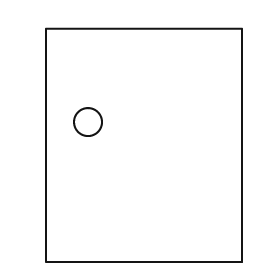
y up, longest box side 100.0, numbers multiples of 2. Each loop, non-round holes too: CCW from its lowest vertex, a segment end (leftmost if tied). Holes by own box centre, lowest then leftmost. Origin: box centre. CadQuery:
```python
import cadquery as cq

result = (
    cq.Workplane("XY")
    .moveTo(-42.0, -50.0)
    .lineTo(42.0, -50.0)
    .lineTo(42.0, 50.0)
    .lineTo(-42.0, 50.0)
    .close()
    .moveTo(-24.0, 10.0)
    .circle(6.0)
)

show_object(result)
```